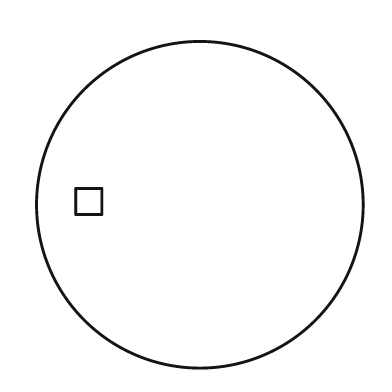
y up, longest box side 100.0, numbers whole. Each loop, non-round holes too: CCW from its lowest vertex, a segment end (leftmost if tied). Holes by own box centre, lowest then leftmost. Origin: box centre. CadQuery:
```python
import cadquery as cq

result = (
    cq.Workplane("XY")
    .moveTo(0.0, 0.0)
    .circle(50.0)
    .moveTo(-38.0, -3.0)
    .lineTo(-30.0, -3.0)
    .lineTo(-30.0, 5.0)
    .lineTo(-38.0, 5.0)
    .close()
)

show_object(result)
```